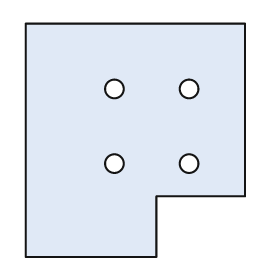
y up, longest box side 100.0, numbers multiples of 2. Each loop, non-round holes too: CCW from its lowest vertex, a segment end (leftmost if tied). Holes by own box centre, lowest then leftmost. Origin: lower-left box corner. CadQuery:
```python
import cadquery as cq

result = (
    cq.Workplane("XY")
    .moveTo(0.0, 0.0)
    .lineTo(56.0, 0.0)
    .lineTo(56.0, 26.0)
    .lineTo(94.0, 26.0)
    .lineTo(94.0, 100.0)
    .lineTo(0.0, 100.0)
    .close()
    .moveTo(38.0, 40.0)
    .circle(4.0)
    .moveTo(70.0, 40.0)
    .circle(4.0)
    .moveTo(38.0, 72.0)
    .circle(4.0)
    .moveTo(70.0, 72.0)
    .circle(4.0)
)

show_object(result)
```